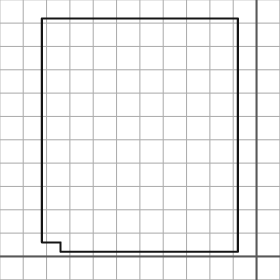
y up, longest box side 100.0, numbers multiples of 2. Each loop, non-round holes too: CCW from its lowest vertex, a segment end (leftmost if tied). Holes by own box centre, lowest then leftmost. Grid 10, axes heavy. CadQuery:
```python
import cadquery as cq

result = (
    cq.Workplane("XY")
    .moveTo(-84.0, 2.0)
    .lineTo(-8.0, 2.0)
    .lineTo(-8.0, 102.0)
    .lineTo(-92.0, 102.0)
    .lineTo(-92.0, 6.0)
    .lineTo(-84.0, 6.0)
    .close()
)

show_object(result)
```